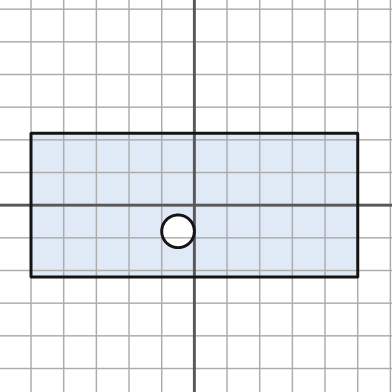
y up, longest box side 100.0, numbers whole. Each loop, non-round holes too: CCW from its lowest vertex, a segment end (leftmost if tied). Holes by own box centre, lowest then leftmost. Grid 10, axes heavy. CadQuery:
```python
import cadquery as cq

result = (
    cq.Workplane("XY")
    .moveTo(-50.0, -22.0)
    .lineTo(50.0, -22.0)
    .lineTo(50.0, 22.0)
    .lineTo(-50.0, 22.0)
    .close()
    .moveTo(-5.0, -8.0)
    .circle(5.0)
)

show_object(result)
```